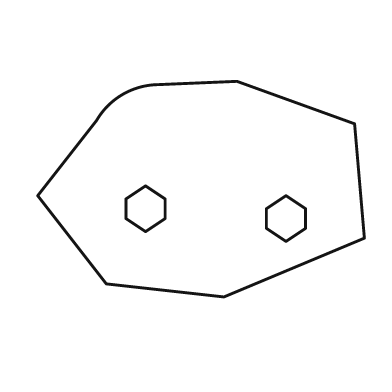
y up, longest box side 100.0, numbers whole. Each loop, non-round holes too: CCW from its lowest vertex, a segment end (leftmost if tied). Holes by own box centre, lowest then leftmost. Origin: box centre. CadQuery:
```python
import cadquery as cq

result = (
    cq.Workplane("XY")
    .moveTo(7.0, -33.0)
    .lineTo(50.0, -15.0)
    .lineTo(47.0, 20.0)
    .lineTo(11.0, 33.0)
    .lineTo(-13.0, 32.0)
    .threePointArc((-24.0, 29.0), (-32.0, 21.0))
    .lineTo(-50.0, -2.0)
    .lineTo(-29.0, -29.0)
    .close()
    .moveTo(26.0, -16.0)
    .lineTo(32.0, -12.0)
    .lineTo(32.0, -6.0)
    .lineTo(26.0, -2.0)
    .lineTo(20.0, -6.0)
    .lineTo(20.0, -12.0)
    .close()
    .moveTo(-17.0, -13.0)
    .lineTo(-11.0, -9.0)
    .lineTo(-11.0, -3.0)
    .lineTo(-17.0, 1.0)
    .lineTo(-23.0, -3.0)
    .lineTo(-23.0, -9.0)
    .close()
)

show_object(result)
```